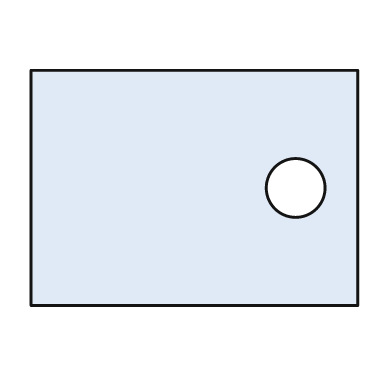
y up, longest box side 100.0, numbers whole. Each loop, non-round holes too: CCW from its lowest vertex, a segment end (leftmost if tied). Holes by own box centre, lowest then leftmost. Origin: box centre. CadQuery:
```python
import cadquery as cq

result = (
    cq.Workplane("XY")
    .moveTo(-50.0, -36.0)
    .lineTo(50.0, -36.0)
    .lineTo(50.0, 36.0)
    .lineTo(-50.0, 36.0)
    .close()
    .moveTo(31.0, 0.0)
    .circle(9.0)
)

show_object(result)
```